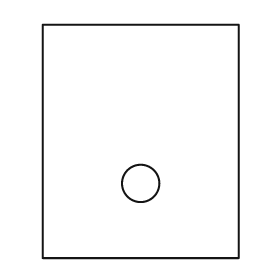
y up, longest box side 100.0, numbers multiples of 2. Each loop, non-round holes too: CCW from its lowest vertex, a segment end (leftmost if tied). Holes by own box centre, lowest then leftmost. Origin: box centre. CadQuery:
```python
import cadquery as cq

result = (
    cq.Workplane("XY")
    .moveTo(-42.0, -50.0)
    .lineTo(42.0, -50.0)
    .lineTo(42.0, 50.0)
    .lineTo(-42.0, 50.0)
    .close()
    .moveTo(0.0, -18.0)
    .circle(8.0)
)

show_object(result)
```